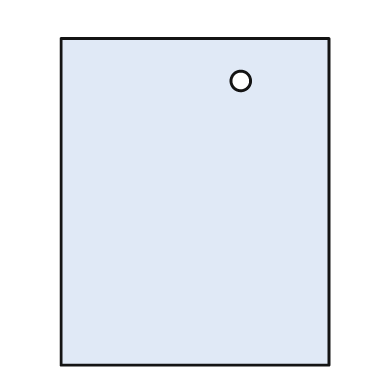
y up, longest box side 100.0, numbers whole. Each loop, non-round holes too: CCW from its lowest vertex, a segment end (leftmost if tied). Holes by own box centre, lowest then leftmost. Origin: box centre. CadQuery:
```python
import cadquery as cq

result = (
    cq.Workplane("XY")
    .moveTo(-41.0, -50.0)
    .lineTo(41.0, -50.0)
    .lineTo(41.0, 50.0)
    .lineTo(-41.0, 50.0)
    .close()
    .moveTo(14.0, 37.0)
    .circle(3.0)
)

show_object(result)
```